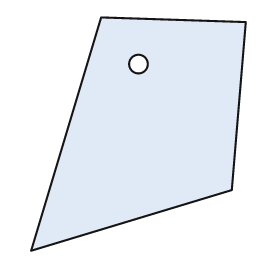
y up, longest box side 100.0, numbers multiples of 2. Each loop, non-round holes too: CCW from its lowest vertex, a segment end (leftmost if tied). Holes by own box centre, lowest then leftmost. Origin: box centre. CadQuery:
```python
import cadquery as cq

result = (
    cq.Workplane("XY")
    .moveTo(-46.0, -50.0)
    .lineTo(40.0, -24.0)
    .lineTo(46.0, 48.0)
    .lineTo(-16.0, 50.0)
    .close()
    .moveTo(0.0, 30.0)
    .circle(4.0)
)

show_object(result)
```